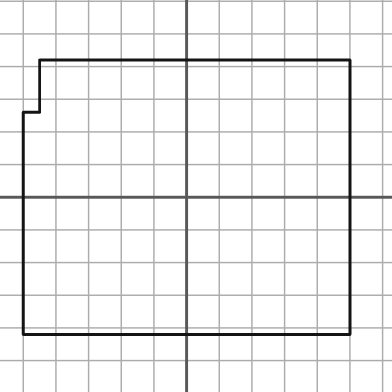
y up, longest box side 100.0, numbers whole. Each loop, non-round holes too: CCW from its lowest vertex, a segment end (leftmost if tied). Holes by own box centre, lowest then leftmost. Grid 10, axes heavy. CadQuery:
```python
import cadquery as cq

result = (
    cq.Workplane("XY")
    .moveTo(-50.0, -42.0)
    .lineTo(50.0, -42.0)
    .lineTo(50.0, 42.0)
    .lineTo(-45.0, 42.0)
    .lineTo(-45.0, 26.0)
    .lineTo(-50.0, 26.0)
    .close()
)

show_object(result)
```